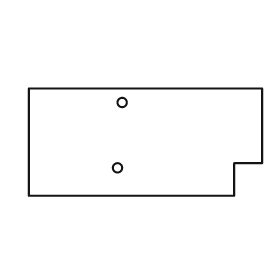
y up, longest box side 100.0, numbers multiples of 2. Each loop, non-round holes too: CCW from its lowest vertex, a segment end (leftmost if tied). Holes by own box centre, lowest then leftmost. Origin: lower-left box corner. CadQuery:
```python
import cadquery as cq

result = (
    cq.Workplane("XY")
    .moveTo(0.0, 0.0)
    .lineTo(88.0, 0.0)
    .lineTo(88.0, 14.0)
    .lineTo(100.0, 14.0)
    .lineTo(100.0, 46.0)
    .lineTo(0.0, 46.0)
    .close()
    .moveTo(38.0, 12.0)
    .circle(2.0)
    .moveTo(40.0, 40.0)
    .circle(2.0)
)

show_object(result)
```